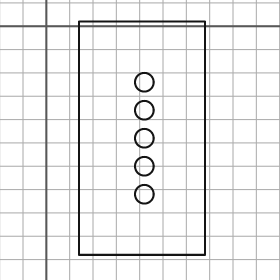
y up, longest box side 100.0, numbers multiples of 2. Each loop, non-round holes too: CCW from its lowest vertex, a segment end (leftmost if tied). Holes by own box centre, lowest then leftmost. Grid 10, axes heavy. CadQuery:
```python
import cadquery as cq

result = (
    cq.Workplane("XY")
    .moveTo(14.0, -98.0)
    .lineTo(68.0, -98.0)
    .lineTo(68.0, 2.0)
    .lineTo(14.0, 2.0)
    .close()
    .moveTo(42.0, -72.0)
    .circle(4.0)
    .moveTo(42.0, -60.0)
    .circle(4.0)
    .moveTo(42.0, -48.0)
    .circle(4.0)
    .moveTo(42.0, -36.0)
    .circle(4.0)
    .moveTo(42.0, -24.0)
    .circle(4.0)
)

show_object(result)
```